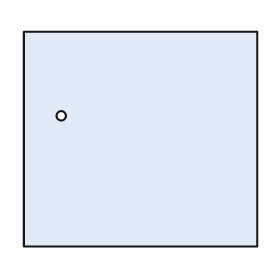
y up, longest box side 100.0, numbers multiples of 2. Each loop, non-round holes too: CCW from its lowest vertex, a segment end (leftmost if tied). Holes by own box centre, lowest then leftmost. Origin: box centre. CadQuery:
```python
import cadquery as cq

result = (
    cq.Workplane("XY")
    .moveTo(-50.0, -46.0)
    .lineTo(50.0, -46.0)
    .lineTo(50.0, 46.0)
    .lineTo(-50.0, 46.0)
    .close()
    .moveTo(-34.0, 10.0)
    .circle(2.0)
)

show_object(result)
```